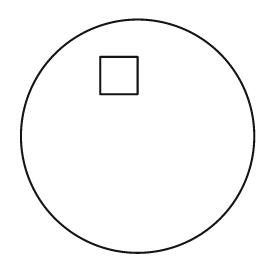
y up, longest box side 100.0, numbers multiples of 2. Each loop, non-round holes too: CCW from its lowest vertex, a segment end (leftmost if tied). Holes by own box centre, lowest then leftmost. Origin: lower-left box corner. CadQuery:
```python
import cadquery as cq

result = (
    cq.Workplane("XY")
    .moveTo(50.0, 50.0)
    .circle(50.0)
    .moveTo(34.0, 68.0)
    .lineTo(50.0, 68.0)
    .lineTo(50.0, 84.0)
    .lineTo(34.0, 84.0)
    .close()
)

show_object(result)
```